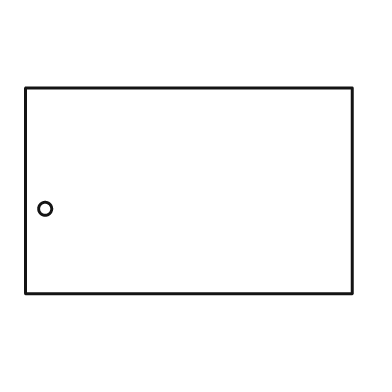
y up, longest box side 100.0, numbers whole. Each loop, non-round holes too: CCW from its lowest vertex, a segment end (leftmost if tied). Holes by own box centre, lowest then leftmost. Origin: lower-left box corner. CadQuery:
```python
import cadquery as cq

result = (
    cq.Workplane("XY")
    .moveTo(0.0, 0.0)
    .lineTo(100.0, 0.0)
    .lineTo(100.0, 63.0)
    .lineTo(0.0, 63.0)
    .close()
    .moveTo(6.0, 26.0)
    .circle(2.0)
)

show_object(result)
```